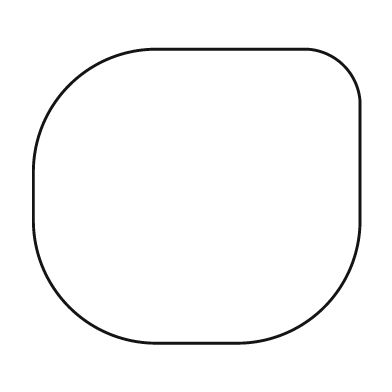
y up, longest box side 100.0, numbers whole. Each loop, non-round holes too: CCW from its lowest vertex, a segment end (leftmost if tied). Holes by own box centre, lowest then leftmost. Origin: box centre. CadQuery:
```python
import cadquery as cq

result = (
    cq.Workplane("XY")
    .moveTo(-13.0, -45.0)
    .lineTo(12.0, -45.0)
    .threePointArc((39.0, -34.0), (50.0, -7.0))
    .lineTo(50.0, 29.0)
    .threePointArc((45.0, 40.0), (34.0, 45.0))
    .lineTo(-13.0, 45.0)
    .threePointArc((-39.0, 34.0), (-50.0, 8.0))
    .lineTo(-50.0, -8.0)
    .threePointArc((-39.0, -34.0), (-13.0, -45.0))
    .close()
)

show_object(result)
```